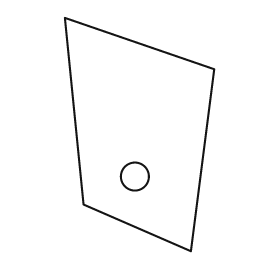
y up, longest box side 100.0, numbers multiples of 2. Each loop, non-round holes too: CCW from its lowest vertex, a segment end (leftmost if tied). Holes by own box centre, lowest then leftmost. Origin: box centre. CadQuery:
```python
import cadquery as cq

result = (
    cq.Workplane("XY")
    .moveTo(22.0, -50.0)
    .lineTo(32.0, 28.0)
    .lineTo(-32.0, 50.0)
    .lineTo(-24.0, -30.0)
    .close()
    .moveTo(-2.0, -18.0)
    .circle(6.0)
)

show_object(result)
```